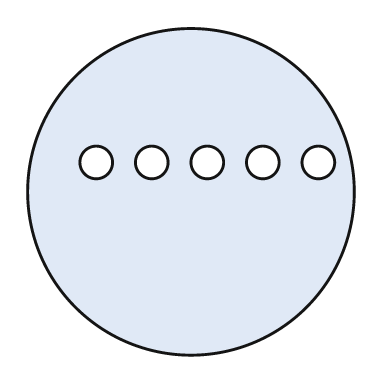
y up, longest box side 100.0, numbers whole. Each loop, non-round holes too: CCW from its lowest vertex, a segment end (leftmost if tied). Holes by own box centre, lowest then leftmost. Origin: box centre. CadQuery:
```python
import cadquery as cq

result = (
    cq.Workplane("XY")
    .moveTo(0.0, 0.0)
    .circle(50.0)
    .moveTo(-29.0, 9.0)
    .circle(5.0)
    .moveTo(-12.0, 9.0)
    .circle(5.0)
    .moveTo(5.0, 9.0)
    .circle(5.0)
    .moveTo(22.0, 9.0)
    .circle(5.0)
    .moveTo(39.0, 9.0)
    .circle(5.0)
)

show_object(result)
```